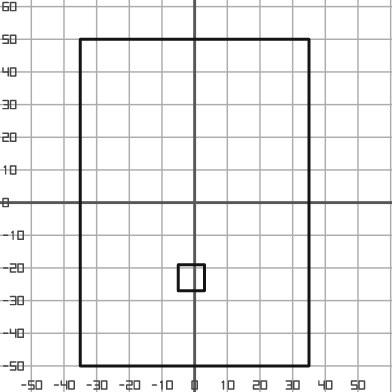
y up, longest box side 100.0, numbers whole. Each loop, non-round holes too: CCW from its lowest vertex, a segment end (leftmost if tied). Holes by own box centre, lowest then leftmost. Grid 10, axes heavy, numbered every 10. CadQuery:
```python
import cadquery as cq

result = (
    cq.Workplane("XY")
    .moveTo(-35.0, -50.0)
    .lineTo(35.0, -50.0)
    .lineTo(35.0, 50.0)
    .lineTo(-35.0, 50.0)
    .close()
    .moveTo(-5.0, -27.0)
    .lineTo(3.0, -27.0)
    .lineTo(3.0, -19.0)
    .lineTo(-5.0, -19.0)
    .close()
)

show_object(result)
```